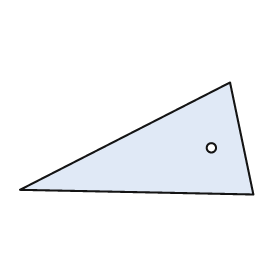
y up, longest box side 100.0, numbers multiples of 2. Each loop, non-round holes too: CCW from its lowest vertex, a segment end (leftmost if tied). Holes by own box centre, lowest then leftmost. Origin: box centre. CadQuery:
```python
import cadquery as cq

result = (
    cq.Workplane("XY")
    .moveTo(50.0, -24.0)
    .lineTo(40.0, 24.0)
    .lineTo(-50.0, -22.0)
    .close()
    .moveTo(32.0, -4.0)
    .circle(2.0)
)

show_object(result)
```